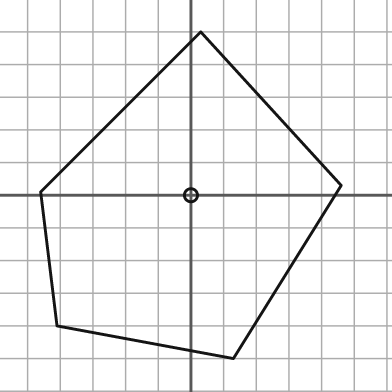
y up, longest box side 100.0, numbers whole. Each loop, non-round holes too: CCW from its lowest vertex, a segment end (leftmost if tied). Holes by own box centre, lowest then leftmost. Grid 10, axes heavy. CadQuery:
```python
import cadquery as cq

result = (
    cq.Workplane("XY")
    .moveTo(13.0, -50.0)
    .lineTo(46.0, 3.0)
    .lineTo(3.0, 50.0)
    .lineTo(-46.0, 1.0)
    .lineTo(-41.0, -40.0)
    .close()
    .moveTo(0.0, 0.0)
    .circle(2.0)
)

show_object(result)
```